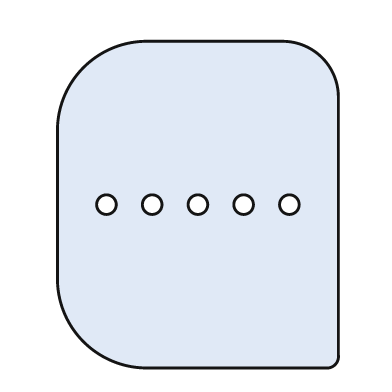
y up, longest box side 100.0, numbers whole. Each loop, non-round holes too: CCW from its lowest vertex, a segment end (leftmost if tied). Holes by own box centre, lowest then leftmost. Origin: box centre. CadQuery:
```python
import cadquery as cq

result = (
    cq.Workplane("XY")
    .moveTo(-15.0, -50.0)
    .lineTo(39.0, -50.0)
    .threePointArc((42.0, -49.0), (43.0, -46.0))
    .lineTo(43.0, 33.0)
    .threePointArc((38.0, 45.0), (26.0, 50.0))
    .lineTo(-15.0, 50.0)
    .threePointArc((-35.0, 42.0), (-43.0, 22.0))
    .lineTo(-43.0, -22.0)
    .threePointArc((-35.0, -42.0), (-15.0, -50.0))
    .close()
    .moveTo(-28.0, 0.0)
    .circle(3.0)
    .moveTo(-14.0, 0.0)
    .circle(3.0)
    .moveTo(0.0, 0.0)
    .circle(3.0)
    .moveTo(14.0, 0.0)
    .circle(3.0)
    .moveTo(28.0, 0.0)
    .circle(3.0)
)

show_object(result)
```